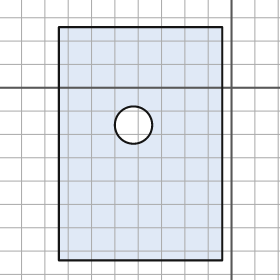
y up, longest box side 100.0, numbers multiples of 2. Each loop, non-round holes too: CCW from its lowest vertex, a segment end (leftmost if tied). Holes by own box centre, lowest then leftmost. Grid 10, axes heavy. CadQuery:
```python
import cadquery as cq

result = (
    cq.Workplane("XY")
    .moveTo(-74.0, -74.0)
    .lineTo(-4.0, -74.0)
    .lineTo(-4.0, 26.0)
    .lineTo(-74.0, 26.0)
    .close()
    .moveTo(-42.0, -16.0)
    .circle(8.0)
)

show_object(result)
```